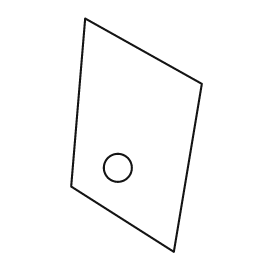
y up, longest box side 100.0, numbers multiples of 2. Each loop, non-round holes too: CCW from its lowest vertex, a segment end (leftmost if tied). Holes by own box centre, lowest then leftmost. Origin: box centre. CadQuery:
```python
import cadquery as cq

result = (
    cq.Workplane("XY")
    .moveTo(16.0, -50.0)
    .lineTo(28.0, 22.0)
    .lineTo(-22.0, 50.0)
    .lineTo(-28.0, -22.0)
    .close()
    .moveTo(-8.0, -14.0)
    .circle(6.0)
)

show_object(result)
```